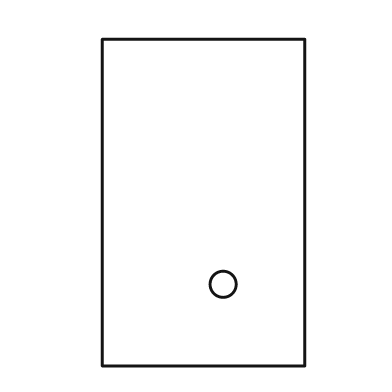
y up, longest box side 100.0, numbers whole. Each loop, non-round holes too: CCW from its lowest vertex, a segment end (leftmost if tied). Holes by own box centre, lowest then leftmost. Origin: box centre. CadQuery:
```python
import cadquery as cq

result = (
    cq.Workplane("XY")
    .moveTo(-31.0, -50.0)
    .lineTo(31.0, -50.0)
    .lineTo(31.0, 50.0)
    .lineTo(-31.0, 50.0)
    .close()
    .moveTo(6.0, -25.0)
    .circle(4.0)
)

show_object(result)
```